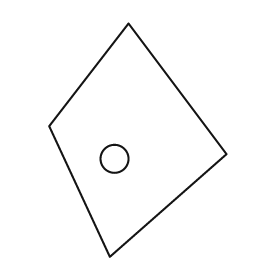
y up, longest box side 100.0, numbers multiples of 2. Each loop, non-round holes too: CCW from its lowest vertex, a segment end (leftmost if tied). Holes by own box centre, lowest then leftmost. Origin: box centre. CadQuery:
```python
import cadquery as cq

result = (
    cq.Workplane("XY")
    .moveTo(-12.0, -50.0)
    .lineTo(38.0, -6.0)
    .lineTo(-4.0, 50.0)
    .lineTo(-38.0, 6.0)
    .close()
    .moveTo(-10.0, -8.0)
    .circle(6.0)
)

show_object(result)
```